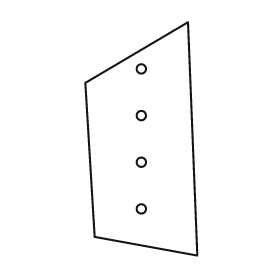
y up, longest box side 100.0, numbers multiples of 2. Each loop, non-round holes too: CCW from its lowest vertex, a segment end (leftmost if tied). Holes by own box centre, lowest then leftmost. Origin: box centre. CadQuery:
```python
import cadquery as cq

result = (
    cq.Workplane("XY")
    .moveTo(24.0, -50.0)
    .lineTo(20.0, 50.0)
    .lineTo(-24.0, 24.0)
    .lineTo(-20.0, -42.0)
    .close()
    .moveTo(0.0, -30.0)
    .circle(2.0)
    .moveTo(0.0, -10.0)
    .circle(2.0)
    .moveTo(0.0, 10.0)
    .circle(2.0)
    .moveTo(0.0, 30.0)
    .circle(2.0)
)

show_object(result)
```